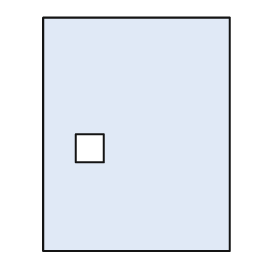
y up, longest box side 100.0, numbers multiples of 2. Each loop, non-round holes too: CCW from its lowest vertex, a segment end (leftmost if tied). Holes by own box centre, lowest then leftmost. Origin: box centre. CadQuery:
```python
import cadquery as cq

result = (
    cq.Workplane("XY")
    .moveTo(-40.0, -50.0)
    .lineTo(40.0, -50.0)
    .lineTo(40.0, 50.0)
    .lineTo(-40.0, 50.0)
    .close()
    .moveTo(-26.0, -12.0)
    .lineTo(-14.0, -12.0)
    .lineTo(-14.0, 0.0)
    .lineTo(-26.0, 0.0)
    .close()
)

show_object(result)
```